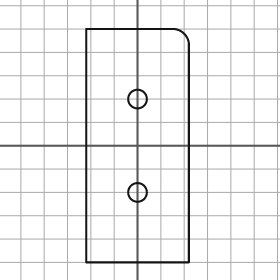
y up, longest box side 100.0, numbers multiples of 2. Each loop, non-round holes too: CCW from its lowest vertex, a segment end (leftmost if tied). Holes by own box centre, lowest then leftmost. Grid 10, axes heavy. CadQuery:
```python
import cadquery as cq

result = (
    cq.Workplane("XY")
    .moveTo(-22.0, -50.0)
    .lineTo(22.0, -50.0)
    .lineTo(22.0, 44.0)
    .threePointArc((20.0, 48.0), (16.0, 50.0))
    .lineTo(-22.0, 50.0)
    .close()
    .moveTo(0.0, -20.0)
    .circle(4.0)
    .moveTo(0.0, 20.0)
    .circle(4.0)
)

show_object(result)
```